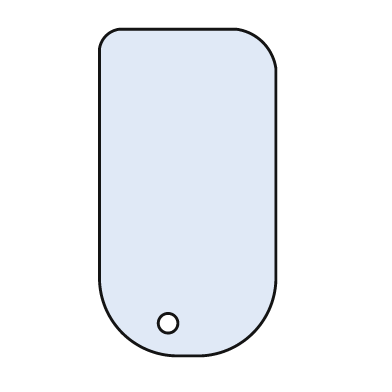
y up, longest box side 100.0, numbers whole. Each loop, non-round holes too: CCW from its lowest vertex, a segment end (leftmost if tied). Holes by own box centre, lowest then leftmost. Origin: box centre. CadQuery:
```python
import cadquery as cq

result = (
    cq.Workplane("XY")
    .moveTo(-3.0, -50.0)
    .lineTo(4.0, -50.0)
    .threePointArc((20.0, -43.0), (27.0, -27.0))
    .lineTo(27.0, 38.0)
    .threePointArc((23.0, 46.0), (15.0, 50.0))
    .lineTo(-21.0, 50.0)
    .threePointArc((-25.0, 48.0), (-27.0, 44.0))
    .lineTo(-27.0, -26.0)
    .threePointArc((-20.0, -43.0), (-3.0, -50.0))
    .close()
    .moveTo(-6.0, -40.0)
    .circle(3.0)
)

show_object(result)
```